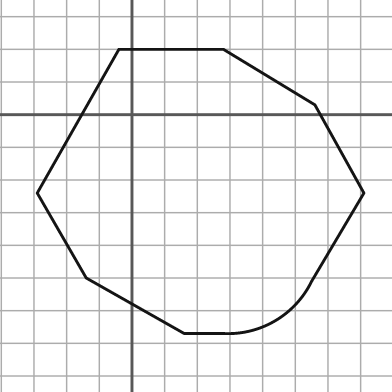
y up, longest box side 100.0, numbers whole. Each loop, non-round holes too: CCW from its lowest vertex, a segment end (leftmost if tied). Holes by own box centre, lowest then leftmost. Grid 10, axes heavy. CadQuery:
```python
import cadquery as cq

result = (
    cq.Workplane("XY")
    .moveTo(16.0, -67.0)
    .lineTo(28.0, -67.0)
    .threePointArc((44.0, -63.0), (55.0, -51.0))
    .lineTo(71.0, -24.0)
    .lineTo(56.0, 3.0)
    .lineTo(28.0, 20.0)
    .lineTo(-4.0, 20.0)
    .lineTo(-29.0, -24.0)
    .lineTo(-14.0, -50.0)
    .close()
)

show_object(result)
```